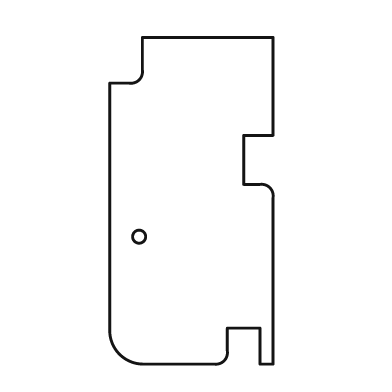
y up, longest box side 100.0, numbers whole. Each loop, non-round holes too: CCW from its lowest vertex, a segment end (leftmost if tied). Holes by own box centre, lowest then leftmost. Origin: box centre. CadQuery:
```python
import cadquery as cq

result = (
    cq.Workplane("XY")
    .moveTo(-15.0, -50.0)
    .lineTo(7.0, -50.0)
    .threePointArc((10.0, -49.0), (11.0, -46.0))
    .lineTo(11.0, -39.0)
    .lineTo(21.0, -39.0)
    .lineTo(21.0, -50.0)
    .lineTo(25.0, -50.0)
    .lineTo(25.0, 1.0)
    .threePointArc((24.0, 4.0), (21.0, 5.0))
    .lineTo(16.0, 5.0)
    .lineTo(16.0, 20.0)
    .lineTo(25.0, 20.0)
    .lineTo(25.0, 50.0)
    .lineTo(-15.0, 50.0)
    .lineTo(-15.0, 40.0)
    .threePointArc((-16.0, 37.0), (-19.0, 36.0))
    .lineTo(-25.0, 36.0)
    .lineTo(-25.0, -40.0)
    .threePointArc((-22.0, -47.0), (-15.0, -50.0))
    .close()
    .moveTo(-16.0, -11.0)
    .circle(2.0)
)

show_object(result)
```